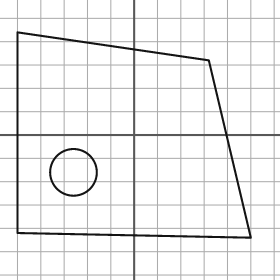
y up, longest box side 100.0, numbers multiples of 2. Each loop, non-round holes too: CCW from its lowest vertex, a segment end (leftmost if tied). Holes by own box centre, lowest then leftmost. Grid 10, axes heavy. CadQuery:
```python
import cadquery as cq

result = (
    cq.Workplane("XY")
    .moveTo(50.0, -44.0)
    .lineTo(32.0, 32.0)
    .lineTo(-50.0, 44.0)
    .lineTo(-50.0, -42.0)
    .close()
    .moveTo(-26.0, -16.0)
    .circle(10.0)
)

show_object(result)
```